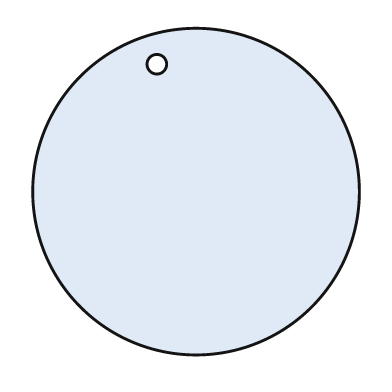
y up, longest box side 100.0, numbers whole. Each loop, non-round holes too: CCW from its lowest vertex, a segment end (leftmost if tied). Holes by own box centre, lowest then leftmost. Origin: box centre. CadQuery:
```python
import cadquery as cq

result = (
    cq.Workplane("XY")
    .moveTo(0.0, 0.0)
    .circle(50.0)
    .moveTo(-12.0, 39.0)
    .circle(3.0)
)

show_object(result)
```